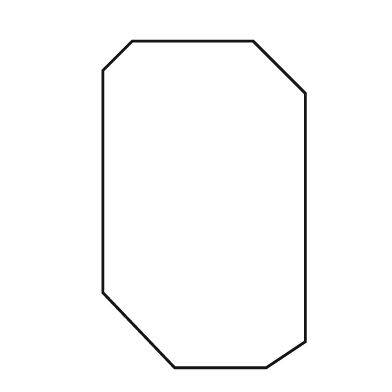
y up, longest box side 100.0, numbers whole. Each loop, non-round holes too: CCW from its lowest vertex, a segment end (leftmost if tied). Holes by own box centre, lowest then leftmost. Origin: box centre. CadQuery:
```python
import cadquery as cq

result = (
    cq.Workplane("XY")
    .moveTo(-9.0, -50.0)
    .lineTo(19.0, -50.0)
    .lineTo(31.0, -42.0)
    .lineTo(31.0, 34.0)
    .lineTo(15.0, 50.0)
    .lineTo(-22.0, 50.0)
    .lineTo(-31.0, 41.0)
    .lineTo(-31.0, -27.0)
    .close()
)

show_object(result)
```